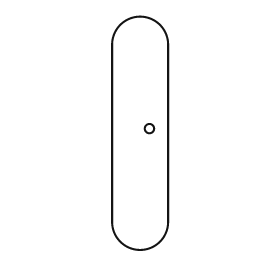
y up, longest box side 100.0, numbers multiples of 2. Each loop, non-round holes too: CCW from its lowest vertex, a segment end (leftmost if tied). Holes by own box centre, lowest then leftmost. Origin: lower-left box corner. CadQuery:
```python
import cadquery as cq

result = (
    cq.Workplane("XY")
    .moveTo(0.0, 12.0)
    .threePointArc((12.0, 0.0), (24.0, 12.0))
    .lineTo(24.0, 88.0)
    .threePointArc((12.0, 100.0), (0.0, 88.0))
    .close()
    .moveTo(16.0, 52.0)
    .circle(2.0)
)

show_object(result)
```